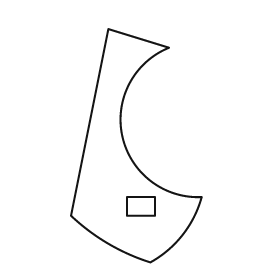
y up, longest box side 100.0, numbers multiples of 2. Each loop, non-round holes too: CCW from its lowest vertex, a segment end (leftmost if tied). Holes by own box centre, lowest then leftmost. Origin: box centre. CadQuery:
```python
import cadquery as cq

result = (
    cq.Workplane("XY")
    .moveTo(6.0, -50.0)
    .threePointArc((20.0, -38.0), (28.0, -22.0))
    .threePointArc((-6.0, 4.0), (14.0, 42.0))
    .lineTo(-12.0, 50.0)
    .lineTo(-28.0, -30.0)
    .threePointArc((-12.0, -42.0), (6.0, -50.0))
    .close()
    .moveTo(-4.0, -30.0)
    .lineTo(8.0, -30.0)
    .lineTo(8.0, -22.0)
    .lineTo(-4.0, -22.0)
    .close()
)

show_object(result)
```